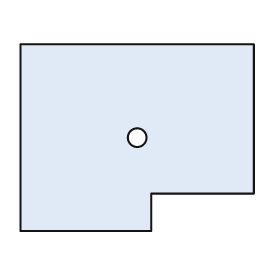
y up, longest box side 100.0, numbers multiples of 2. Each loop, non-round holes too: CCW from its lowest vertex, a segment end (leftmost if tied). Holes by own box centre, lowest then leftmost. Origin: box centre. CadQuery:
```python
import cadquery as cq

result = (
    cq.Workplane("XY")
    .moveTo(-50.0, -40.0)
    .lineTo(6.0, -40.0)
    .lineTo(6.0, -24.0)
    .lineTo(50.0, -24.0)
    .lineTo(50.0, 40.0)
    .lineTo(-50.0, 40.0)
    .close()
    .moveTo(0.0, 0.0)
    .circle(4.0)
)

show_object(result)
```